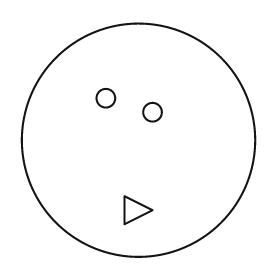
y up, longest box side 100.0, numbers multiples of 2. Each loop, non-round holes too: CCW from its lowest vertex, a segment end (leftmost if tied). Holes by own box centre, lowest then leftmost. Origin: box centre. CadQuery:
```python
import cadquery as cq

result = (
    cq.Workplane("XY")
    .moveTo(0.0, 0.0)
    .circle(50.0)
    .moveTo(-6.0, -36.0)
    .lineTo(6.0, -30.0)
    .lineTo(-6.0, -24.0)
    .close()
    .moveTo(6.0, 12.0)
    .circle(4.0)
    .moveTo(-14.0, 18.0)
    .circle(4.0)
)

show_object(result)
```